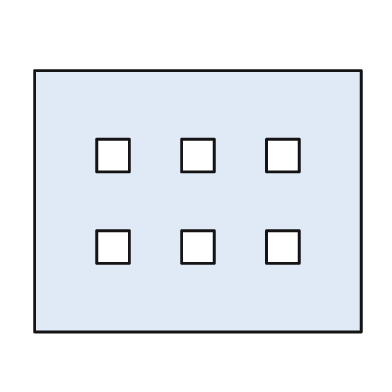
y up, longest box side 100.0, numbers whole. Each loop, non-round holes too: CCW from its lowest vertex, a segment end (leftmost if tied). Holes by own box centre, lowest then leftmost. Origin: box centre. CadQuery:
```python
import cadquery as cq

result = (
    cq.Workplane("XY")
    .moveTo(-50.0, -40.0)
    .lineTo(50.0, -40.0)
    .lineTo(50.0, 40.0)
    .lineTo(-50.0, 40.0)
    .close()
    .moveTo(-31.0, -19.0)
    .lineTo(-21.0, -19.0)
    .lineTo(-21.0, -9.0)
    .lineTo(-31.0, -9.0)
    .close()
    .moveTo(-5.0, -19.0)
    .lineTo(5.0, -19.0)
    .lineTo(5.0, -9.0)
    .lineTo(-5.0, -9.0)
    .close()
    .moveTo(21.0, -19.0)
    .lineTo(31.0, -19.0)
    .lineTo(31.0, -9.0)
    .lineTo(21.0, -9.0)
    .close()
    .moveTo(-31.0, 9.0)
    .lineTo(-21.0, 9.0)
    .lineTo(-21.0, 19.0)
    .lineTo(-31.0, 19.0)
    .close()
    .moveTo(-5.0, 9.0)
    .lineTo(5.0, 9.0)
    .lineTo(5.0, 19.0)
    .lineTo(-5.0, 19.0)
    .close()
    .moveTo(21.0, 9.0)
    .lineTo(31.0, 9.0)
    .lineTo(31.0, 19.0)
    .lineTo(21.0, 19.0)
    .close()
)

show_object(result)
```